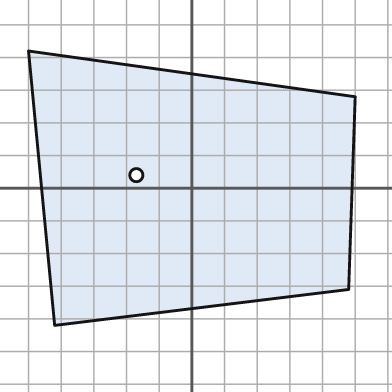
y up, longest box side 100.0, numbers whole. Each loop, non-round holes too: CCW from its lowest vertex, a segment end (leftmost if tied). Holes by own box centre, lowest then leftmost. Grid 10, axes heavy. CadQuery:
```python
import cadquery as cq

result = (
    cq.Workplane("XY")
    .moveTo(-42.0, -42.0)
    .lineTo(48.0, -31.0)
    .lineTo(50.0, 28.0)
    .lineTo(-50.0, 42.0)
    .close()
    .moveTo(-17.0, 4.0)
    .circle(2.0)
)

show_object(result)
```